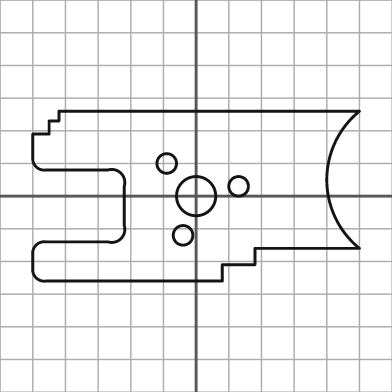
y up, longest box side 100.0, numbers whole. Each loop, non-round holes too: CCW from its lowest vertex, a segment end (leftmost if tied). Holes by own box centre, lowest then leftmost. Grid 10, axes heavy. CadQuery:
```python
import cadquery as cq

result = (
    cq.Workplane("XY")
    .moveTo(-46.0, -26.0)
    .lineTo(8.0, -26.0)
    .lineTo(8.0, -21.0)
    .lineTo(18.0, -21.0)
    .lineTo(18.0, -16.0)
    .lineTo(50.0, -16.0)
    .threePointArc((40.0, 5.0), (50.0, 26.0))
    .lineTo(-42.0, 26.0)
    .lineTo(-42.0, 23.0)
    .lineTo(-45.0, 23.0)
    .lineTo(-45.0, 19.0)
    .lineTo(-50.0, 19.0)
    .lineTo(-50.0, 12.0)
    .threePointArc((-49.0, 9.0), (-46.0, 8.0))
    .lineTo(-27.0, 8.0)
    .threePointArc((-23.0, 7.0), (-22.0, 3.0))
    .lineTo(-22.0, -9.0)
    .threePointArc((-23.0, -13.0), (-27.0, -14.0))
    .lineTo(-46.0, -14.0)
    .threePointArc((-49.0, -15.0), (-50.0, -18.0))
    .lineTo(-50.0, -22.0)
    .threePointArc((-49.0, -25.0), (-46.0, -26.0))
    .close()
    .moveTo(-4.0, -12.0)
    .circle(3.0)
    .moveTo(0.0, 0.0)
    .circle(6.0)
    .moveTo(13.0, 3.0)
    .circle(3.0)
    .moveTo(-9.0, 10.0)
    .circle(3.0)
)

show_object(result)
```